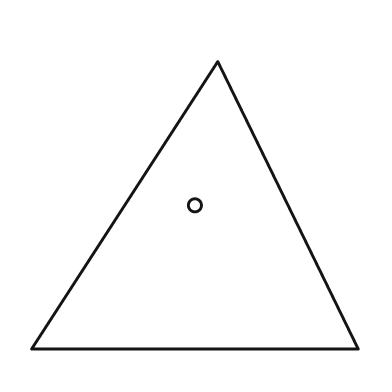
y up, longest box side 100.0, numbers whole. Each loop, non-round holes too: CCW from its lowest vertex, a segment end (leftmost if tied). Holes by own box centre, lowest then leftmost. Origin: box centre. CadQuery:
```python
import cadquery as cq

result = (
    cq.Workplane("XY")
    .moveTo(-50.0, -44.0)
    .lineTo(50.0, -44.0)
    .lineTo(7.0, 44.0)
    .close()
    .moveTo(0.0, 0.0)
    .circle(2.0)
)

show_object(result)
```